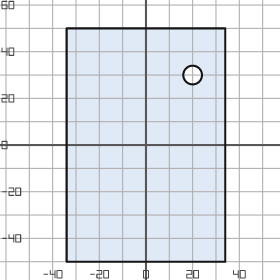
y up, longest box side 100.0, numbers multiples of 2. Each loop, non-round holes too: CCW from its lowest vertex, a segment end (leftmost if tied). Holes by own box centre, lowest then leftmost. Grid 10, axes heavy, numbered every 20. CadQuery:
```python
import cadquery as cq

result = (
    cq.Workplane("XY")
    .moveTo(-34.0, -50.0)
    .lineTo(34.0, -50.0)
    .lineTo(34.0, 50.0)
    .lineTo(-34.0, 50.0)
    .close()
    .moveTo(20.0, 30.0)
    .circle(4.0)
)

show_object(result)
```